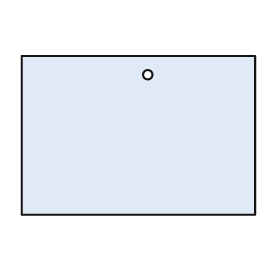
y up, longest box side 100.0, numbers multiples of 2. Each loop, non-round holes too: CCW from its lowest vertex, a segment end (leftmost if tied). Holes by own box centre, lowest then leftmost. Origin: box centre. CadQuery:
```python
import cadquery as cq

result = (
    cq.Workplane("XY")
    .moveTo(-50.0, -34.0)
    .lineTo(50.0, -34.0)
    .lineTo(50.0, 34.0)
    .lineTo(-50.0, 34.0)
    .close()
    .moveTo(4.0, 26.0)
    .circle(2.0)
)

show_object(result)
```